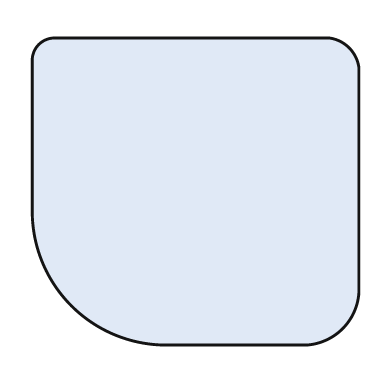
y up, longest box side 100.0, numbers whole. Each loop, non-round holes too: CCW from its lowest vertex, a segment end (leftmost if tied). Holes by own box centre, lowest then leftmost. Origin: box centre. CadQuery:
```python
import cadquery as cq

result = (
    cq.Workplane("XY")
    .moveTo(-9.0, -47.0)
    .lineTo(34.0, -47.0)
    .threePointArc((45.0, -42.0), (50.0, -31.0))
    .lineTo(50.0, 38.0)
    .threePointArc((47.0, 44.0), (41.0, 47.0))
    .lineTo(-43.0, 47.0)
    .threePointArc((-48.0, 45.0), (-50.0, 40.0))
    .lineTo(-50.0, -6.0)
    .threePointArc((-38.0, -35.0), (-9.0, -47.0))
    .close()
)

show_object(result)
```